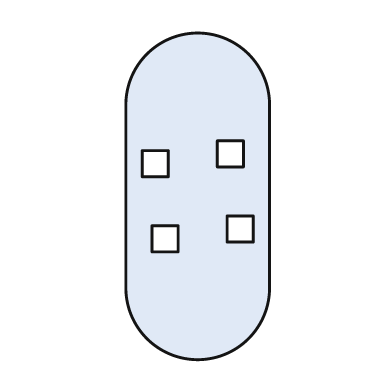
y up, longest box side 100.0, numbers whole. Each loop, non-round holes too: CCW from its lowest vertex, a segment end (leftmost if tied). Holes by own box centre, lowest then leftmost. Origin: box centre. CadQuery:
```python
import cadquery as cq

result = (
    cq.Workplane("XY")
    .moveTo(-22.0, -28.0)
    .threePointArc((0.0, -50.0), (22.0, -28.0))
    .lineTo(22.0, 28.0)
    .threePointArc((0.0, 50.0), (-22.0, 28.0))
    .close()
    .moveTo(-14.0, -17.0)
    .lineTo(-6.0, -17.0)
    .lineTo(-6.0, -9.0)
    .lineTo(-14.0, -9.0)
    .close()
    .moveTo(9.0, -14.0)
    .lineTo(17.0, -14.0)
    .lineTo(17.0, -6.0)
    .lineTo(9.0, -6.0)
    .close()
    .moveTo(-17.0, 6.0)
    .lineTo(-9.0, 6.0)
    .lineTo(-9.0, 14.0)
    .lineTo(-17.0, 14.0)
    .close()
    .moveTo(6.0, 9.0)
    .lineTo(14.0, 9.0)
    .lineTo(14.0, 17.0)
    .lineTo(6.0, 17.0)
    .close()
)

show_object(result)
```